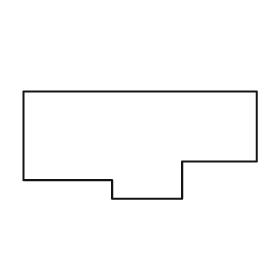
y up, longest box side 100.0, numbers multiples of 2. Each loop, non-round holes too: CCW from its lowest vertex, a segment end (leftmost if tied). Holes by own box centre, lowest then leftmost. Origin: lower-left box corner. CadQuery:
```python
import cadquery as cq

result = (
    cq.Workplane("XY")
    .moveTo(38.0, 0.0)
    .lineTo(68.0, 0.0)
    .lineTo(68.0, 16.0)
    .lineTo(100.0, 16.0)
    .lineTo(100.0, 46.0)
    .lineTo(0.0, 46.0)
    .lineTo(0.0, 8.0)
    .lineTo(38.0, 8.0)
    .close()
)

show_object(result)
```